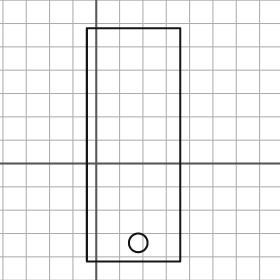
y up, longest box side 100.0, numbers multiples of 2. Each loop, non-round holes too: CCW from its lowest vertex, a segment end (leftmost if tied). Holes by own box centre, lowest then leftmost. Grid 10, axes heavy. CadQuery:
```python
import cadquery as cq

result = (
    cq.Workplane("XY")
    .moveTo(-4.0, -42.0)
    .lineTo(36.0, -42.0)
    .lineTo(36.0, 58.0)
    .lineTo(-4.0, 58.0)
    .close()
    .moveTo(18.0, -34.0)
    .circle(4.0)
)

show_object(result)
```